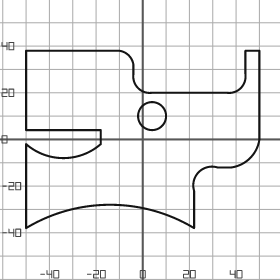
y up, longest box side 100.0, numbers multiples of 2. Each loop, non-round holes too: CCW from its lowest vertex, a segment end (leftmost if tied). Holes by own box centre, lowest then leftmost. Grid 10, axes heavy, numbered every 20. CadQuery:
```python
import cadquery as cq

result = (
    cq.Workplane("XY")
    .moveTo(-50.0, -38.0)
    .threePointArc((-14.0, -28.0), (22.0, -38.0))
    .lineTo(22.0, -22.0)
    .threePointArc((24.0, -14.0), (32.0, -12.0))
    .lineTo(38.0, -12.0)
    .threePointArc((46.0, -8.0), (50.0, 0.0))
    .lineTo(50.0, 38.0)
    .lineTo(44.0, 38.0)
    .lineTo(44.0, 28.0)
    .threePointArc((42.0, 22.0), (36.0, 20.0))
    .lineTo(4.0, 20.0)
    .threePointArc((-2.0, 22.0), (-4.0, 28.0))
    .lineTo(-4.0, 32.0)
    .threePointArc((-6.0, 36.0), (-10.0, 38.0))
    .lineTo(-50.0, 38.0)
    .lineTo(-50.0, 4.0)
    .lineTo(-18.0, 4.0)
    .lineTo(-18.0, -2.0)
    .threePointArc((-34.0, -8.0), (-50.0, -2.0))
    .close()
    .moveTo(4.0, 10.0)
    .circle(6.0)
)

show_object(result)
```